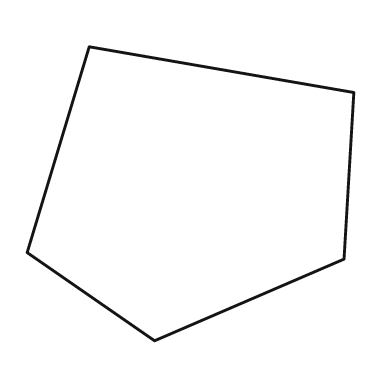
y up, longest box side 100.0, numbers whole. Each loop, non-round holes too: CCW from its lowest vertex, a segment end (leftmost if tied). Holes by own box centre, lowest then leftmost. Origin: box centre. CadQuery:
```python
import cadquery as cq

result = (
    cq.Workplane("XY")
    .moveTo(-11.0, -45.0)
    .lineTo(47.0, -20.0)
    .lineTo(50.0, 31.0)
    .lineTo(-31.0, 45.0)
    .lineTo(-50.0, -18.0)
    .close()
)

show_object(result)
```